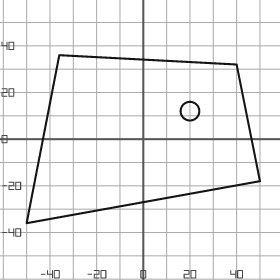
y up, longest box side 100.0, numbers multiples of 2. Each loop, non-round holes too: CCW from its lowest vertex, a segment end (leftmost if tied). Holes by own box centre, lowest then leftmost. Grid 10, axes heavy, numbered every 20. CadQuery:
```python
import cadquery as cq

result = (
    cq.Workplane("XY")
    .moveTo(-50.0, -36.0)
    .lineTo(50.0, -18.0)
    .lineTo(40.0, 32.0)
    .lineTo(-36.0, 36.0)
    .close()
    .moveTo(20.0, 12.0)
    .circle(4.0)
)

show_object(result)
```